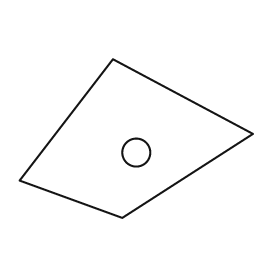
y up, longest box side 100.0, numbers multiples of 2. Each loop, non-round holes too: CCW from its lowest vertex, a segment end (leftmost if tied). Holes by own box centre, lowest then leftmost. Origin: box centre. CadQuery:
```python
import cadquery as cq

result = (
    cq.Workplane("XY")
    .moveTo(-6.0, -34.0)
    .lineTo(50.0, 2.0)
    .lineTo(-10.0, 34.0)
    .lineTo(-50.0, -18.0)
    .close()
    .moveTo(0.0, -6.0)
    .circle(6.0)
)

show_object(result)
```